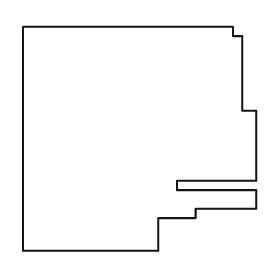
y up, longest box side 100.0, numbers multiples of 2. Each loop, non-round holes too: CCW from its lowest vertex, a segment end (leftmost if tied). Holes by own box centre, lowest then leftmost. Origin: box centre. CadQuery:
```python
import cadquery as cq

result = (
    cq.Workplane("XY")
    .moveTo(-50.0, -48.0)
    .lineTo(8.0, -48.0)
    .lineTo(8.0, -34.0)
    .lineTo(24.0, -34.0)
    .lineTo(24.0, -30.0)
    .lineTo(50.0, -30.0)
    .lineTo(50.0, -22.0)
    .lineTo(16.0, -22.0)
    .lineTo(16.0, -18.0)
    .lineTo(50.0, -18.0)
    .lineTo(50.0, 12.0)
    .lineTo(44.0, 12.0)
    .lineTo(44.0, 44.0)
    .lineTo(40.0, 44.0)
    .lineTo(40.0, 48.0)
    .lineTo(-50.0, 48.0)
    .close()
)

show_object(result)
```